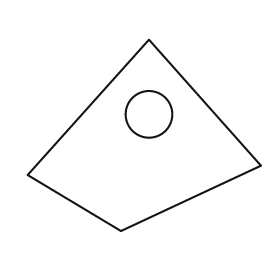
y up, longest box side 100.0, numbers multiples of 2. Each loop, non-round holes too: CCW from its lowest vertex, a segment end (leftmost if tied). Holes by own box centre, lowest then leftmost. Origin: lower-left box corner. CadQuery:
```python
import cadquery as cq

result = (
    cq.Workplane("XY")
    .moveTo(40.0, 0.0)
    .lineTo(100.0, 28.0)
    .lineTo(52.0, 82.0)
    .lineTo(0.0, 24.0)
    .close()
    .moveTo(52.0, 50.0)
    .circle(10.0)
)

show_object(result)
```